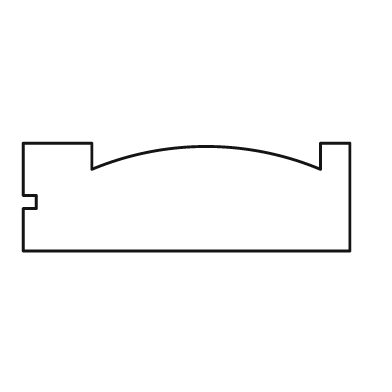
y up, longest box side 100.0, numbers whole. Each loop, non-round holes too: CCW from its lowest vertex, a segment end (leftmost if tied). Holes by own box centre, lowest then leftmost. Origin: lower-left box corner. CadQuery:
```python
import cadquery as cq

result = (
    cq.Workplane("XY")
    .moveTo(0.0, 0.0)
    .lineTo(100.0, 0.0)
    .lineTo(100.0, 33.0)
    .lineTo(91.0, 33.0)
    .lineTo(91.0, 25.0)
    .threePointArc((56.0, 32.0), (21.0, 25.0))
    .lineTo(21.0, 33.0)
    .lineTo(0.0, 33.0)
    .lineTo(0.0, 17.0)
    .lineTo(4.0, 17.0)
    .lineTo(4.0, 13.0)
    .lineTo(0.0, 13.0)
    .close()
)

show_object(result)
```